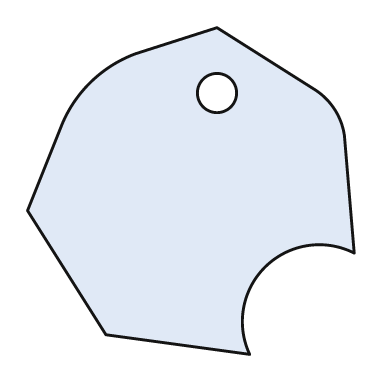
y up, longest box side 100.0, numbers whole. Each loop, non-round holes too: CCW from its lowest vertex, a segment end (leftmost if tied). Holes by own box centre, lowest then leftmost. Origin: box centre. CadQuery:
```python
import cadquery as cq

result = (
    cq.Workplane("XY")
    .moveTo(18.0, -50.0)
    .threePointArc((23.0, -23.0), (50.0, -19.0))
    .lineTo(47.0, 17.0)
    .threePointArc((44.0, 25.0), (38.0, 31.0))
    .lineTo(8.0, 50.0)
    .lineTo(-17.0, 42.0)
    .threePointArc((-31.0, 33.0), (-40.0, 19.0))
    .lineTo(-50.0, -6.0)
    .lineTo(-26.0, -44.0)
    .close()
    .moveTo(8.0, 30.0)
    .circle(6.0)
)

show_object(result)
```